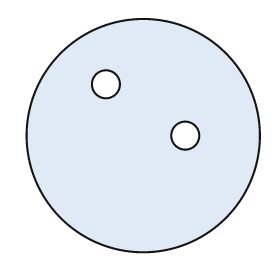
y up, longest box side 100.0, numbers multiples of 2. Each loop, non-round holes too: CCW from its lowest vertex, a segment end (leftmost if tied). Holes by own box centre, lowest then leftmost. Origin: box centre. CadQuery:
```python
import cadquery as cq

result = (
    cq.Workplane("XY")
    .moveTo(0.0, 0.0)
    .circle(50.0)
    .moveTo(18.0, 0.0)
    .circle(6.0)
    .moveTo(-16.0, 22.0)
    .circle(6.0)
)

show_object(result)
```